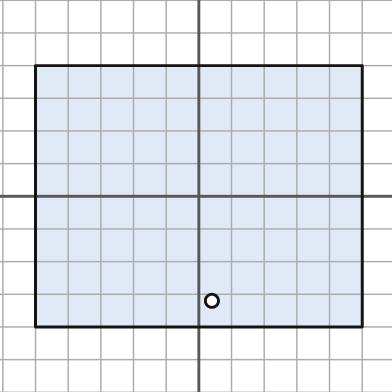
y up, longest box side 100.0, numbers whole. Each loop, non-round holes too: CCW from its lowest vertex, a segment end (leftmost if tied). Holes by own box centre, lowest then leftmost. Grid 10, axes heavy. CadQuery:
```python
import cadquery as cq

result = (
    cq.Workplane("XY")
    .moveTo(-50.0, -40.0)
    .lineTo(50.0, -40.0)
    .lineTo(50.0, 40.0)
    .lineTo(-50.0, 40.0)
    .close()
    .moveTo(4.0, -32.0)
    .circle(2.0)
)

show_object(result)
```